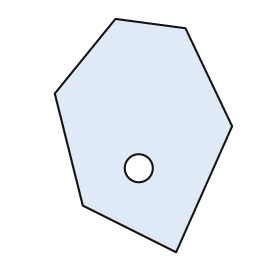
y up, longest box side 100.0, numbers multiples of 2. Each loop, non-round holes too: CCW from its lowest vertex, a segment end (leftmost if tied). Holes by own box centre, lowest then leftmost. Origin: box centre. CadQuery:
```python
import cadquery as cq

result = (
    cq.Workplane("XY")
    .moveTo(14.0, -50.0)
    .lineTo(38.0, 4.0)
    .lineTo(18.0, 46.0)
    .lineTo(-12.0, 50.0)
    .lineTo(-38.0, 18.0)
    .lineTo(-26.0, -30.0)
    .close()
    .moveTo(-2.0, -14.0)
    .circle(6.0)
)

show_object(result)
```